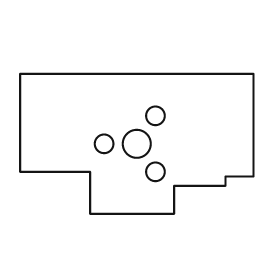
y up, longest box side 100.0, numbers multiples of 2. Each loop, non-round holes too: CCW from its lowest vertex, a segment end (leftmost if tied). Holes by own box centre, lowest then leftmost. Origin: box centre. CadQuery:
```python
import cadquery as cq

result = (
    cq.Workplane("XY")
    .moveTo(-20.0, -30.0)
    .lineTo(16.0, -30.0)
    .lineTo(16.0, -18.0)
    .lineTo(38.0, -18.0)
    .lineTo(38.0, -14.0)
    .lineTo(50.0, -14.0)
    .lineTo(50.0, 30.0)
    .lineTo(-50.0, 30.0)
    .lineTo(-50.0, -12.0)
    .lineTo(-20.0, -12.0)
    .close()
    .moveTo(8.0, -12.0)
    .circle(4.0)
    .moveTo(-14.0, 0.0)
    .circle(4.0)
    .moveTo(0.0, 0.0)
    .circle(6.0)
    .moveTo(8.0, 12.0)
    .circle(4.0)
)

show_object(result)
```